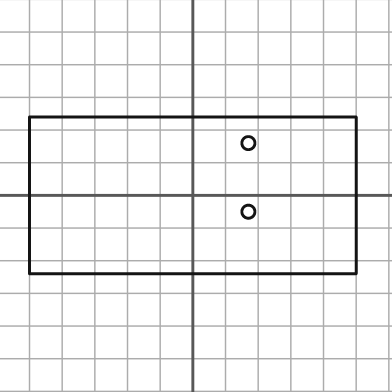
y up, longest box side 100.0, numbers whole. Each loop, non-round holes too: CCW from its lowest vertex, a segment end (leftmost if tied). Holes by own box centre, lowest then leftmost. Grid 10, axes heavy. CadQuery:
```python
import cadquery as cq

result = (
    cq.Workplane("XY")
    .moveTo(-50.0, -24.0)
    .lineTo(50.0, -24.0)
    .lineTo(50.0, 24.0)
    .lineTo(-50.0, 24.0)
    .close()
    .moveTo(17.0, -5.0)
    .circle(2.0)
    .moveTo(17.0, 16.0)
    .circle(2.0)
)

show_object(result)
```